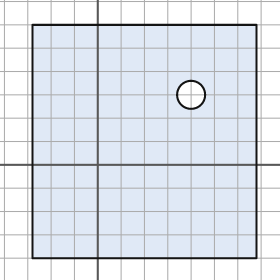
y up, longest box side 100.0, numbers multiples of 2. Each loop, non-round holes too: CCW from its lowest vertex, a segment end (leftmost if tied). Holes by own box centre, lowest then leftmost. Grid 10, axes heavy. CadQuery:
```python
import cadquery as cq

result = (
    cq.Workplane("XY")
    .moveTo(-28.0, -40.0)
    .lineTo(68.0, -40.0)
    .lineTo(68.0, 60.0)
    .lineTo(-28.0, 60.0)
    .close()
    .moveTo(40.0, 30.0)
    .circle(6.0)
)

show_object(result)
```